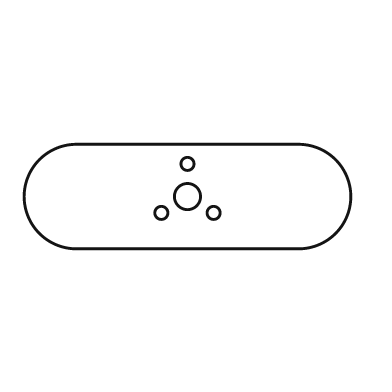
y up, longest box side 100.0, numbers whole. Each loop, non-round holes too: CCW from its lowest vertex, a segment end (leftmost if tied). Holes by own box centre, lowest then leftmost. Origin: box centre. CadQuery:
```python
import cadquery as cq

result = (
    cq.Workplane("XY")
    .moveTo(-34.0, -16.0)
    .lineTo(34.0, -16.0)
    .threePointArc((50.0, 0.0), (34.0, 16.0))
    .lineTo(-34.0, 16.0)
    .threePointArc((-50.0, 0.0), (-34.0, -16.0))
    .close()
    .moveTo(-8.0, -5.0)
    .circle(2.0)
    .moveTo(8.0, -5.0)
    .circle(2.0)
    .moveTo(0.0, 0.0)
    .circle(4.0)
    .moveTo(0.0, 10.0)
    .circle(2.0)
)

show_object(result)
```